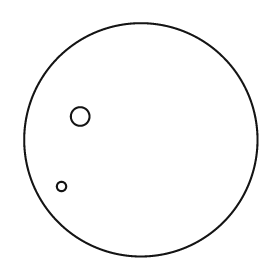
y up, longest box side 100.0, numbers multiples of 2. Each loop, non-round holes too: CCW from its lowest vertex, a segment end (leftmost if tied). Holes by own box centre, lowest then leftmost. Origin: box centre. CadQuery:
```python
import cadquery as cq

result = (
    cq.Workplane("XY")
    .moveTo(0.0, 0.0)
    .circle(50.0)
    .moveTo(-34.0, -20.0)
    .circle(2.0)
    .moveTo(-26.0, 10.0)
    .circle(4.0)
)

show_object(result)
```